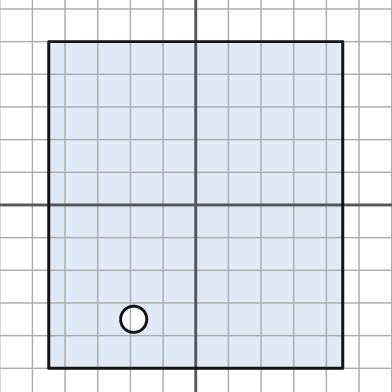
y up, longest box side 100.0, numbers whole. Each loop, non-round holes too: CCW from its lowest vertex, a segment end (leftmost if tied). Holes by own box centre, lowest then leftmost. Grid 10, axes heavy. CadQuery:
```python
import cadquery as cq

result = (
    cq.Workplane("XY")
    .moveTo(-45.0, -50.0)
    .lineTo(45.0, -50.0)
    .lineTo(45.0, 50.0)
    .lineTo(-45.0, 50.0)
    .close()
    .moveTo(-19.0, -35.0)
    .circle(4.0)
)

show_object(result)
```